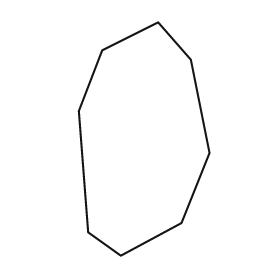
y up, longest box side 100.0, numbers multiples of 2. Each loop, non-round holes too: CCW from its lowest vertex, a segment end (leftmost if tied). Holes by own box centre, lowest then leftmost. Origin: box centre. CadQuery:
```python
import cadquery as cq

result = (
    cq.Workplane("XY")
    .moveTo(-10.0, -50.0)
    .lineTo(16.0, -36.0)
    .lineTo(28.0, -6.0)
    .lineTo(20.0, 34.0)
    .lineTo(6.0, 50.0)
    .lineTo(-18.0, 38.0)
    .lineTo(-28.0, 12.0)
    .lineTo(-24.0, -40.0)
    .close()
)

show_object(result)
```